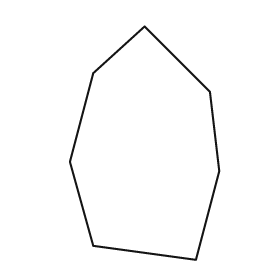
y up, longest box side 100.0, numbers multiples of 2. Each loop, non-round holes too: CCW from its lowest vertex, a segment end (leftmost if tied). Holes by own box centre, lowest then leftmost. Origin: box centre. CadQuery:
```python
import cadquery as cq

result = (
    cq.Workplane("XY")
    .moveTo(22.0, -50.0)
    .lineTo(32.0, -12.0)
    .lineTo(28.0, 22.0)
    .lineTo(0.0, 50.0)
    .lineTo(-22.0, 30.0)
    .lineTo(-32.0, -8.0)
    .lineTo(-22.0, -44.0)
    .close()
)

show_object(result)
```